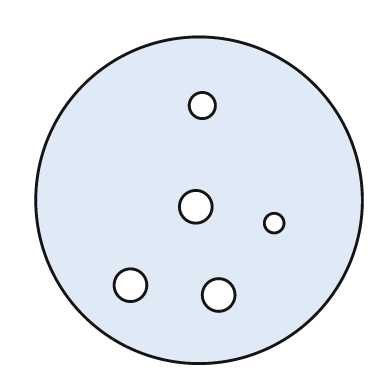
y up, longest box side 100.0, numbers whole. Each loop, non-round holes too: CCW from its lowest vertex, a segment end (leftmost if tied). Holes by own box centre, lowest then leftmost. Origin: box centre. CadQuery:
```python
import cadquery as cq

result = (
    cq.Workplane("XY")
    .moveTo(0.0, 0.0)
    .circle(50.0)
    .moveTo(6.0, -29.0)
    .circle(5.0)
    .moveTo(-21.0, -26.0)
    .circle(5.0)
    .moveTo(23.0, -7.0)
    .circle(3.0)
    .moveTo(-1.0, -2.0)
    .circle(5.0)
    .moveTo(1.0, 29.0)
    .circle(4.0)
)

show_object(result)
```